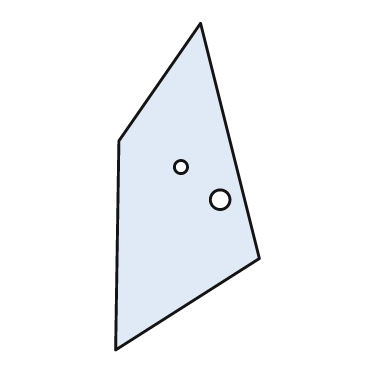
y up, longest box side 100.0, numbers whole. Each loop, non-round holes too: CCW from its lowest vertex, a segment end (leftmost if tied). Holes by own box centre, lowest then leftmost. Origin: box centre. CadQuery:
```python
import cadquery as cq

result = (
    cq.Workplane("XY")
    .moveTo(-22.0, -50.0)
    .lineTo(22.0, -22.0)
    .lineTo(4.0, 50.0)
    .lineTo(-21.0, 14.0)
    .close()
    .moveTo(10.0, -4.0)
    .circle(3.0)
    .moveTo(-2.0, 6.0)
    .circle(2.0)
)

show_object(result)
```